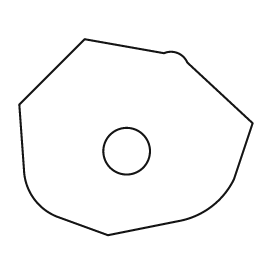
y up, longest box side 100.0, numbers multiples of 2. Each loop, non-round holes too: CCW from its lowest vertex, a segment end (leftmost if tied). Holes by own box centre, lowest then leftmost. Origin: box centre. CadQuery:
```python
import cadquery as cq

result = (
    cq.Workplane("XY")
    .moveTo(-12.0, -42.0)
    .lineTo(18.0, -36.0)
    .threePointArc((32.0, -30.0), (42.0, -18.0))
    .lineTo(50.0, 6.0)
    .lineTo(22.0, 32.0)
    .threePointArc((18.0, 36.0), (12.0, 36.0))
    .lineTo(-22.0, 42.0)
    .lineTo(-50.0, 14.0)
    .lineTo(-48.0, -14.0)
    .threePointArc((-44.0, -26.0), (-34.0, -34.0))
    .close()
    .moveTo(-4.0, -6.0)
    .circle(10.0)
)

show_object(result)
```